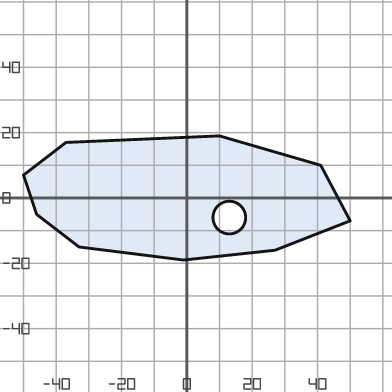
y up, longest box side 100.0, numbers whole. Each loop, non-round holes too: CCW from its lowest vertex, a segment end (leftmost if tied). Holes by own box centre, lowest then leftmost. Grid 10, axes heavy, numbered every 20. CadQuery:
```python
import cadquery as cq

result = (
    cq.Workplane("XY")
    .moveTo(-1.0, -19.0)
    .lineTo(27.0, -16.0)
    .lineTo(50.0, -7.0)
    .lineTo(41.0, 10.0)
    .lineTo(10.0, 19.0)
    .lineTo(-37.0, 17.0)
    .lineTo(-50.0, 7.0)
    .lineTo(-46.0, -5.0)
    .lineTo(-33.0, -15.0)
    .close()
    .moveTo(13.0, -6.0)
    .circle(5.0)
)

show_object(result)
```